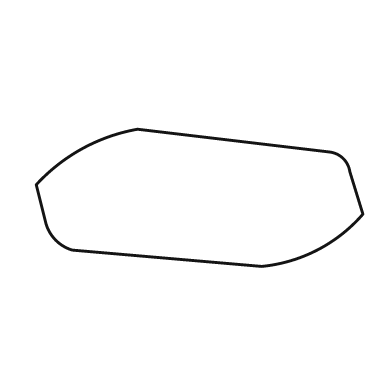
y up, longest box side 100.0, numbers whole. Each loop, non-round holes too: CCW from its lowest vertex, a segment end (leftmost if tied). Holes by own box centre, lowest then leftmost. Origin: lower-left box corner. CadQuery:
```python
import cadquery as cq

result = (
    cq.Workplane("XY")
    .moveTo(69.0, 0.0)
    .threePointArc((86.0, 5.0), (100.0, 16.0))
    .lineTo(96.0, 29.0)
    .threePointArc((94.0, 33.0), (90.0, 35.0))
    .lineTo(31.0, 42.0)
    .threePointArc((14.0, 36.0), (0.0, 25.0))
    .lineTo(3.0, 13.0)
    .threePointArc((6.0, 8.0), (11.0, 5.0))
    .close()
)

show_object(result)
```